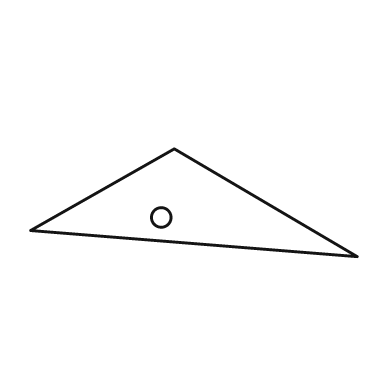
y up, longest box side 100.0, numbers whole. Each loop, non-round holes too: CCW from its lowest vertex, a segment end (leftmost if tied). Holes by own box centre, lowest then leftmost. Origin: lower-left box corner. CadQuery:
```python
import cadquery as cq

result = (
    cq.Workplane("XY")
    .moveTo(100.0, 0.0)
    .lineTo(44.0, 33.0)
    .lineTo(0.0, 8.0)
    .close()
    .moveTo(40.0, 12.0)
    .circle(3.0)
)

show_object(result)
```